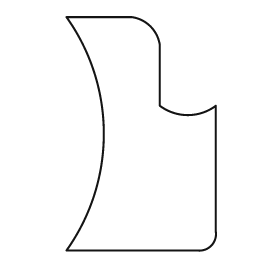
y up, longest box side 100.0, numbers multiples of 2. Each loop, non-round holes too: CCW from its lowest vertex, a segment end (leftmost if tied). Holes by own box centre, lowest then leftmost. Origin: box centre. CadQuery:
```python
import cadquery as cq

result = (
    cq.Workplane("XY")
    .moveTo(-32.0, -50.0)
    .lineTo(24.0, -50.0)
    .threePointArc((30.0, -48.0), (32.0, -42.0))
    .lineTo(32.0, 12.0)
    .threePointArc((20.0, 8.0), (8.0, 12.0))
    .lineTo(8.0, 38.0)
    .threePointArc((4.0, 46.0), (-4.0, 50.0))
    .lineTo(-32.0, 50.0)
    .threePointArc((-16.0, 0.0), (-32.0, -50.0))
    .close()
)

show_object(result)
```